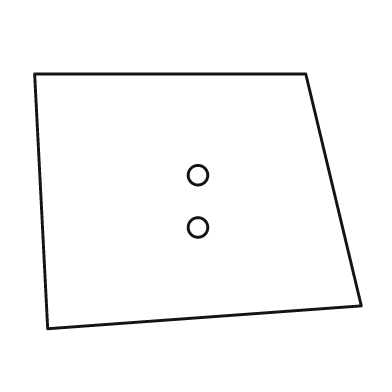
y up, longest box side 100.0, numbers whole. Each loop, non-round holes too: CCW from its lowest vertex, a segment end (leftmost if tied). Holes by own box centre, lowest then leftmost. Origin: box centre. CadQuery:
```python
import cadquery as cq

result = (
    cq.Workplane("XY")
    .moveTo(-46.0, -39.0)
    .lineTo(50.0, -32.0)
    .lineTo(33.0, 39.0)
    .lineTo(-50.0, 39.0)
    .close()
    .moveTo(0.0, -8.0)
    .circle(3.0)
    .moveTo(0.0, 8.0)
    .circle(3.0)
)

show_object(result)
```